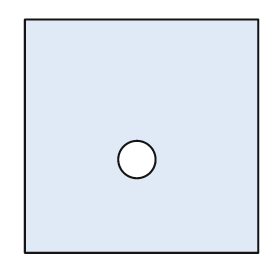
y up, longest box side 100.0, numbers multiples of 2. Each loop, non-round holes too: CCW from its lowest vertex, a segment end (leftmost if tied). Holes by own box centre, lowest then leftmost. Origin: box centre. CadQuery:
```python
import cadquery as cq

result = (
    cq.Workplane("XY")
    .moveTo(-50.0, -50.0)
    .lineTo(50.0, -50.0)
    .lineTo(50.0, 50.0)
    .lineTo(-50.0, 50.0)
    .close()
    .moveTo(-2.0, -10.0)
    .circle(8.0)
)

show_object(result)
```